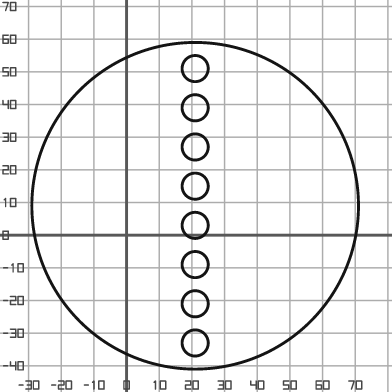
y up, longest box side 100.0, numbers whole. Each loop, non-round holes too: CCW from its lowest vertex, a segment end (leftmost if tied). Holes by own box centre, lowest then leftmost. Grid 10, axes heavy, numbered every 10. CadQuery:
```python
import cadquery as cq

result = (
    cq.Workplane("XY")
    .moveTo(21.0, 9.0)
    .circle(50.0)
    .moveTo(21.0, -33.0)
    .circle(4.0)
    .moveTo(21.0, -21.0)
    .circle(4.0)
    .moveTo(21.0, -9.0)
    .circle(4.0)
    .moveTo(21.0, 3.0)
    .circle(4.0)
    .moveTo(21.0, 15.0)
    .circle(4.0)
    .moveTo(21.0, 27.0)
    .circle(4.0)
    .moveTo(21.0, 39.0)
    .circle(4.0)
    .moveTo(21.0, 51.0)
    .circle(4.0)
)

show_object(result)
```